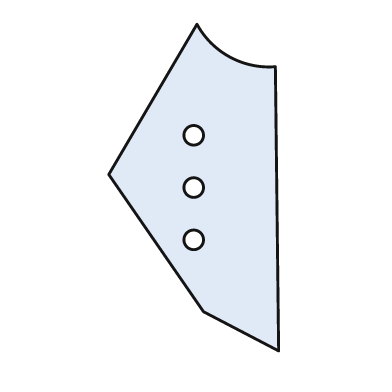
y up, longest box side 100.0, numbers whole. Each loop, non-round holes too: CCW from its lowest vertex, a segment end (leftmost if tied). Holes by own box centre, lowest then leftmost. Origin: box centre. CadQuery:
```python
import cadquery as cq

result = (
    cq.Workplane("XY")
    .moveTo(26.0, -50.0)
    .lineTo(25.0, 37.0)
    .threePointArc((11.0, 40.0), (1.0, 50.0))
    .lineTo(-26.0, 4.0)
    .lineTo(3.0, -38.0)
    .close()
    .moveTo(0.0, -16.0)
    .circle(3.0)
    .moveTo(0.0, 0.0)
    .circle(3.0)
    .moveTo(0.0, 16.0)
    .circle(3.0)
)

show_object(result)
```